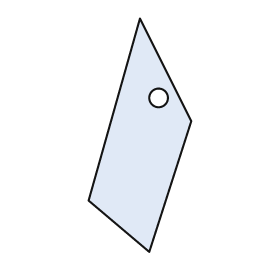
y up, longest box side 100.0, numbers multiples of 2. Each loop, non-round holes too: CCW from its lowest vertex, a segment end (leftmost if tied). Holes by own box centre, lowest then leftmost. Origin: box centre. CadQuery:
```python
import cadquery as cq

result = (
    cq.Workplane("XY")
    .moveTo(4.0, -50.0)
    .lineTo(22.0, 6.0)
    .lineTo(0.0, 50.0)
    .lineTo(-22.0, -28.0)
    .close()
    .moveTo(8.0, 16.0)
    .circle(4.0)
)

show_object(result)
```